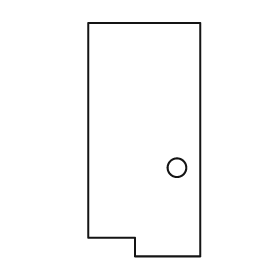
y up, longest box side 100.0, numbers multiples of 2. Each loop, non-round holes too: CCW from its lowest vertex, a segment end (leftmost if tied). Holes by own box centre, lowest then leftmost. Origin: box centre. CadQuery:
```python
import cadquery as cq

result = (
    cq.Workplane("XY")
    .moveTo(-4.0, -50.0)
    .lineTo(24.0, -50.0)
    .lineTo(24.0, 50.0)
    .lineTo(-24.0, 50.0)
    .lineTo(-24.0, -42.0)
    .lineTo(-4.0, -42.0)
    .close()
    .moveTo(14.0, -12.0)
    .circle(4.0)
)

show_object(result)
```